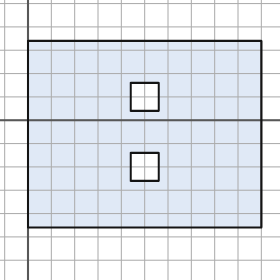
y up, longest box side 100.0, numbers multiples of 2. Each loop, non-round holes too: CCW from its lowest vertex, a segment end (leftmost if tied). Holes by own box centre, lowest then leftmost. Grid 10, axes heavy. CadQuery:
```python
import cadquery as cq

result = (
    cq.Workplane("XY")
    .moveTo(0.0, -46.0)
    .lineTo(100.0, -46.0)
    .lineTo(100.0, 34.0)
    .lineTo(0.0, 34.0)
    .close()
    .moveTo(44.0, -26.0)
    .lineTo(56.0, -26.0)
    .lineTo(56.0, -14.0)
    .lineTo(44.0, -14.0)
    .close()
    .moveTo(44.0, 4.0)
    .lineTo(56.0, 4.0)
    .lineTo(56.0, 16.0)
    .lineTo(44.0, 16.0)
    .close()
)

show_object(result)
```